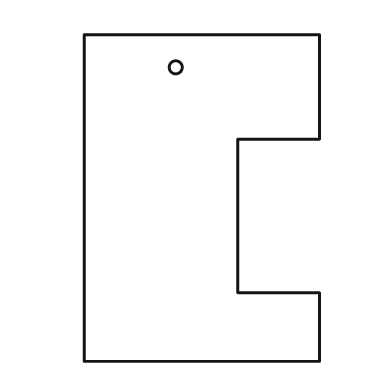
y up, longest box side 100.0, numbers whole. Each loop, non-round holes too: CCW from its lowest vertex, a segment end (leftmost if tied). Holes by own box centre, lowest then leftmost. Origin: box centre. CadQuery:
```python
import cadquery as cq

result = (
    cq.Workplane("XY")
    .moveTo(-36.0, -50.0)
    .lineTo(36.0, -50.0)
    .lineTo(36.0, -29.0)
    .lineTo(11.0, -29.0)
    .lineTo(11.0, 18.0)
    .lineTo(36.0, 18.0)
    .lineTo(36.0, 50.0)
    .lineTo(-36.0, 50.0)
    .close()
    .moveTo(-8.0, 40.0)
    .circle(2.0)
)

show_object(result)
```